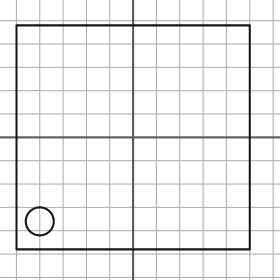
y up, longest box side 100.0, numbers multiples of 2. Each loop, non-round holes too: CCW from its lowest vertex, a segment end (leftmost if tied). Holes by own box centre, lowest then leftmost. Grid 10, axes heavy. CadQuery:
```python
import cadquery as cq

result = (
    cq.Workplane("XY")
    .moveTo(-50.0, -48.0)
    .lineTo(50.0, -48.0)
    .lineTo(50.0, 48.0)
    .lineTo(-50.0, 48.0)
    .close()
    .moveTo(-40.0, -36.0)
    .circle(6.0)
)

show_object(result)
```